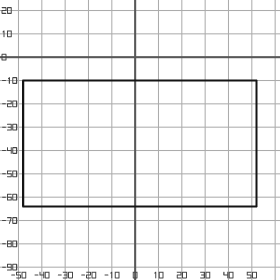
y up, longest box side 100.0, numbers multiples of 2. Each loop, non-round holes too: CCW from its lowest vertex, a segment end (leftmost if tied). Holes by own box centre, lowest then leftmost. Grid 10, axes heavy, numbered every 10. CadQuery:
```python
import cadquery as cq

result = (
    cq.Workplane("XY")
    .moveTo(-48.0, -64.0)
    .lineTo(52.0, -64.0)
    .lineTo(52.0, -10.0)
    .lineTo(-48.0, -10.0)
    .close()
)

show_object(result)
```